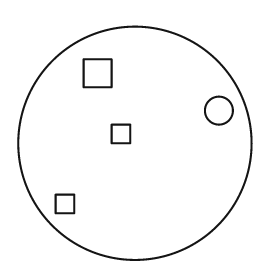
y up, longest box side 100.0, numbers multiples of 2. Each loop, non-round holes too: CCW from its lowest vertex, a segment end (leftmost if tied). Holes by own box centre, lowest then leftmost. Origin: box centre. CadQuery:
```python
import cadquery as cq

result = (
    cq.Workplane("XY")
    .moveTo(0.0, 0.0)
    .circle(50.0)
    .moveTo(-34.0, -30.0)
    .lineTo(-26.0, -30.0)
    .lineTo(-26.0, -22.0)
    .lineTo(-34.0, -22.0)
    .close()
    .moveTo(-10.0, 0.0)
    .lineTo(-2.0, 0.0)
    .lineTo(-2.0, 8.0)
    .lineTo(-10.0, 8.0)
    .close()
    .moveTo(36.0, 14.0)
    .circle(6.0)
    .moveTo(-22.0, 24.0)
    .lineTo(-10.0, 24.0)
    .lineTo(-10.0, 36.0)
    .lineTo(-22.0, 36.0)
    .close()
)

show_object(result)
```